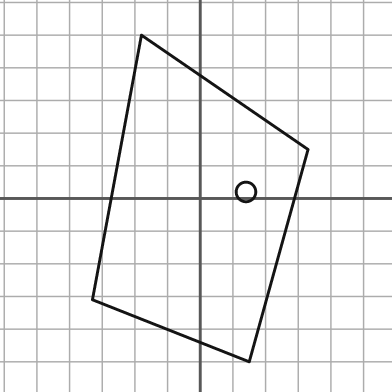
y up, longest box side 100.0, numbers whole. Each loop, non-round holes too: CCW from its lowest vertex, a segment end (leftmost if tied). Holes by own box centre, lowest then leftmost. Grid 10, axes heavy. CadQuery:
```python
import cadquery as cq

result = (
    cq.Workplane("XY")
    .moveTo(15.0, -50.0)
    .lineTo(33.0, 15.0)
    .lineTo(-18.0, 50.0)
    .lineTo(-33.0, -31.0)
    .close()
    .moveTo(14.0, 2.0)
    .circle(3.0)
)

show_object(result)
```